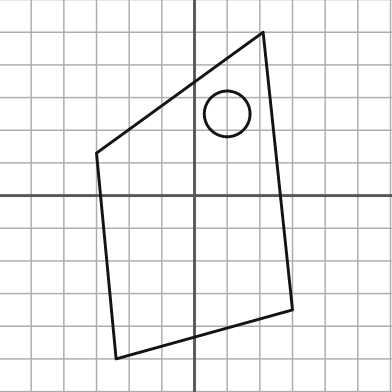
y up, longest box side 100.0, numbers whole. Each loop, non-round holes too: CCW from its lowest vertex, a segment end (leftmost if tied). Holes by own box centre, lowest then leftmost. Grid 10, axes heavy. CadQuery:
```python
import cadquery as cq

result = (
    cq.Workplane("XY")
    .moveTo(-24.0, -50.0)
    .lineTo(30.0, -35.0)
    .lineTo(21.0, 50.0)
    .lineTo(-30.0, 13.0)
    .close()
    .moveTo(10.0, 25.0)
    .circle(7.0)
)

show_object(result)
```